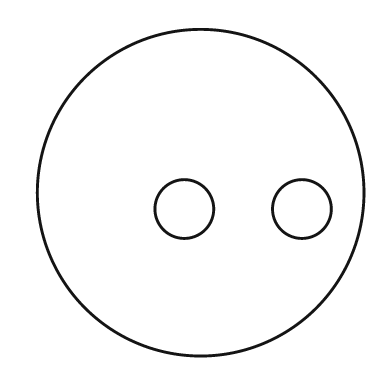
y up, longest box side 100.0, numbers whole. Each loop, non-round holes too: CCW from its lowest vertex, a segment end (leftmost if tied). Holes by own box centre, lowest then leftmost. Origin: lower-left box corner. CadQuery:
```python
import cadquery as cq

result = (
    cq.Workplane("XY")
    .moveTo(50.0, 50.0)
    .circle(50.0)
    .moveTo(45.0, 45.0)
    .circle(9.0)
    .moveTo(81.0, 45.0)
    .circle(9.0)
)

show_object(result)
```